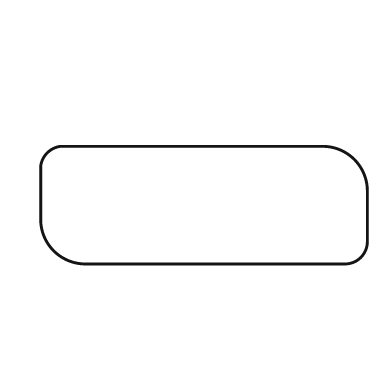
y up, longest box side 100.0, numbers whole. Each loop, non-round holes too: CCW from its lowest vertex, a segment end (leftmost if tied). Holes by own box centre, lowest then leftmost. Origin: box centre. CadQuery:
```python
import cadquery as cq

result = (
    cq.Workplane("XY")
    .moveTo(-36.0, -18.0)
    .lineTo(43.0, -18.0)
    .threePointArc((48.0, -16.0), (50.0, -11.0))
    .lineTo(50.0, 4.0)
    .threePointArc((46.0, 14.0), (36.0, 18.0))
    .lineTo(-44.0, 18.0)
    .threePointArc((-48.0, 16.0), (-50.0, 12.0))
    .lineTo(-50.0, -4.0)
    .threePointArc((-46.0, -14.0), (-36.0, -18.0))
    .close()
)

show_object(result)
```